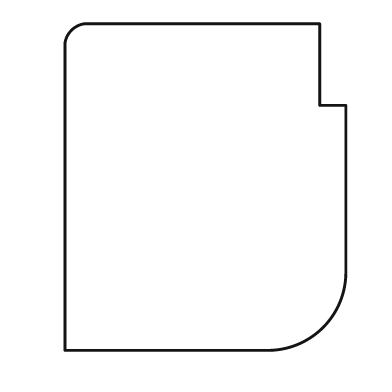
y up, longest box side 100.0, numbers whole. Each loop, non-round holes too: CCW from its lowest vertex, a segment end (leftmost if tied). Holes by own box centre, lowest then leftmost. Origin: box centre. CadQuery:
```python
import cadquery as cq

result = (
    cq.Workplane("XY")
    .moveTo(-43.0, -50.0)
    .lineTo(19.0, -50.0)
    .threePointArc((36.0, -43.0), (43.0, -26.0))
    .lineTo(43.0, 25.0)
    .lineTo(35.0, 25.0)
    .lineTo(35.0, 50.0)
    .lineTo(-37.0, 50.0)
    .threePointArc((-41.0, 48.0), (-43.0, 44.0))
    .close()
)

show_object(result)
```